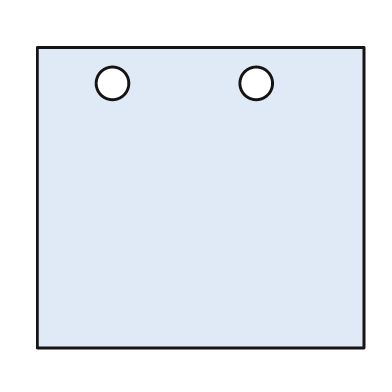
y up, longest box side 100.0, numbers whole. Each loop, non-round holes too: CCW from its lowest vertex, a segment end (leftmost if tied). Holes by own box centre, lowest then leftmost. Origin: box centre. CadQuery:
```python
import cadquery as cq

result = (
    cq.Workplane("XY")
    .moveTo(-50.0, -46.0)
    .lineTo(50.0, -46.0)
    .lineTo(50.0, 46.0)
    .lineTo(-50.0, 46.0)
    .close()
    .moveTo(-27.0, 35.0)
    .circle(5.0)
    .moveTo(17.0, 35.0)
    .circle(5.0)
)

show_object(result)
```